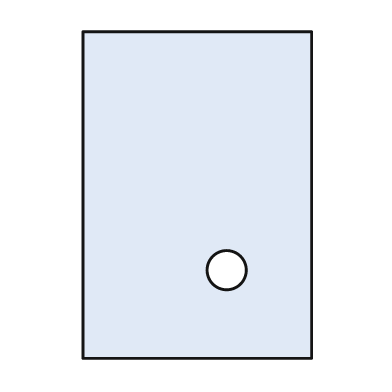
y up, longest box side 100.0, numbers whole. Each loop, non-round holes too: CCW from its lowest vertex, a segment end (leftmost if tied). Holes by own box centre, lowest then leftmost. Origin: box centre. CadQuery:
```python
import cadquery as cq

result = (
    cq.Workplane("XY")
    .moveTo(-35.0, -50.0)
    .lineTo(35.0, -50.0)
    .lineTo(35.0, 50.0)
    .lineTo(-35.0, 50.0)
    .close()
    .moveTo(9.0, -23.0)
    .circle(6.0)
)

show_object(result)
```